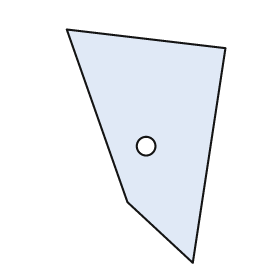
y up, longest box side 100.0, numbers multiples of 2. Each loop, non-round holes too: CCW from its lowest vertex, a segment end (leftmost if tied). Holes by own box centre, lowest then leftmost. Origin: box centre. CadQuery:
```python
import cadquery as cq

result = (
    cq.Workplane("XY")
    .moveTo(20.0, -50.0)
    .lineTo(34.0, 42.0)
    .lineTo(-34.0, 50.0)
    .lineTo(-8.0, -24.0)
    .close()
    .moveTo(0.0, 0.0)
    .circle(4.0)
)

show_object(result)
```